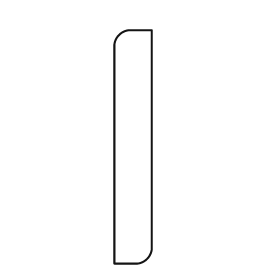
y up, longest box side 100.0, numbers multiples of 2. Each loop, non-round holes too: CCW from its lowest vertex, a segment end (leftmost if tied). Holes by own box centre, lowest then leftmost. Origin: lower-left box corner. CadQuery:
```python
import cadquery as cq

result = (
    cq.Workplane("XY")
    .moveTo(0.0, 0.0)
    .lineTo(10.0, 0.0)
    .threePointArc((14.0, 2.0), (16.0, 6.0))
    .lineTo(16.0, 100.0)
    .lineTo(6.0, 100.0)
    .threePointArc((2.0, 98.0), (0.0, 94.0))
    .close()
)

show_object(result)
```